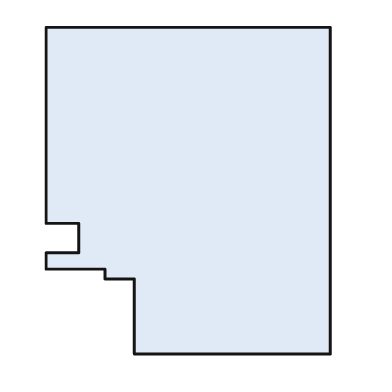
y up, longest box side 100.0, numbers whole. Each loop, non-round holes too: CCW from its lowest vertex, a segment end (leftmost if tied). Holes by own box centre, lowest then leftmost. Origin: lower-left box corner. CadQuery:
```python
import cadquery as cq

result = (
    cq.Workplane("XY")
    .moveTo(27.0, 0.0)
    .lineTo(87.0, 0.0)
    .lineTo(87.0, 100.0)
    .lineTo(0.0, 100.0)
    .lineTo(0.0, 40.0)
    .lineTo(10.0, 40.0)
    .lineTo(10.0, 31.0)
    .lineTo(0.0, 31.0)
    .lineTo(0.0, 26.0)
    .lineTo(18.0, 26.0)
    .lineTo(18.0, 23.0)
    .lineTo(27.0, 23.0)
    .close()
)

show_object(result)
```